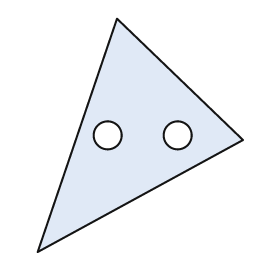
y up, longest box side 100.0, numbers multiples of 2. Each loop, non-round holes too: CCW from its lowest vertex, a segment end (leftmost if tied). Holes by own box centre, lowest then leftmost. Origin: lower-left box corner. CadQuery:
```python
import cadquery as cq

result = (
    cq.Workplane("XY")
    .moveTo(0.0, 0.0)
    .lineTo(88.0, 48.0)
    .lineTo(34.0, 100.0)
    .close()
    .moveTo(30.0, 50.0)
    .circle(6.0)
    .moveTo(60.0, 50.0)
    .circle(6.0)
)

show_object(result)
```